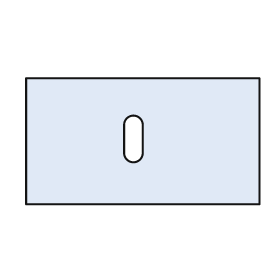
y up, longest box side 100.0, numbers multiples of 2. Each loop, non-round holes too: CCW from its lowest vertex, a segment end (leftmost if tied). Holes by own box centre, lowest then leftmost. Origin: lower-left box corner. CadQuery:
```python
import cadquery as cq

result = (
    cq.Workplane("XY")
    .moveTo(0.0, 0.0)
    .lineTo(100.0, 0.0)
    .lineTo(100.0, 54.0)
    .lineTo(0.0, 54.0)
    .close()
    .moveTo(42.0, 22.0)
    .threePointArc((46.0, 18.0), (50.0, 22.0))
    .lineTo(50.0, 34.0)
    .threePointArc((46.0, 38.0), (42.0, 34.0))
    .close()
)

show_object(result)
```